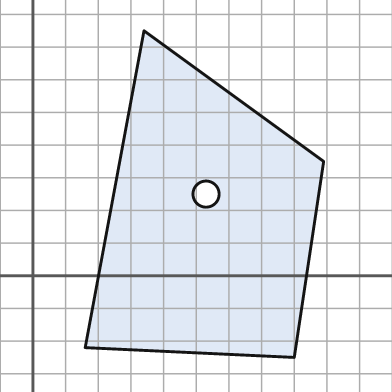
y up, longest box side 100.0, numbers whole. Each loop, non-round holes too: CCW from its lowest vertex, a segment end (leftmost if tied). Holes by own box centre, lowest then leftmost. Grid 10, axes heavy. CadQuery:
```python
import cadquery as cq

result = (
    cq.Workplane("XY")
    .moveTo(80.0, -25.0)
    .lineTo(89.0, 35.0)
    .lineTo(34.0, 75.0)
    .lineTo(16.0, -22.0)
    .close()
    .moveTo(53.0, 25.0)
    .circle(4.0)
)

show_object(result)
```